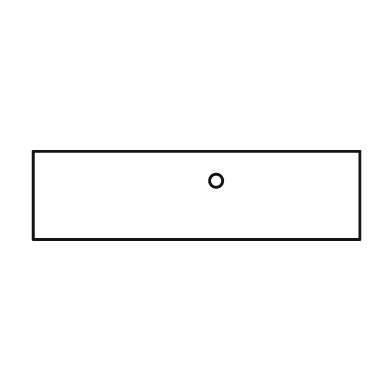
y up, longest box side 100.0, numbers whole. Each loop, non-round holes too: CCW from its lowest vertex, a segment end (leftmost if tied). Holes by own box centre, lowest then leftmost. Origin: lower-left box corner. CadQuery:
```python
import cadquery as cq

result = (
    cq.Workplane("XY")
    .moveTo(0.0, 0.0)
    .lineTo(100.0, 0.0)
    .lineTo(100.0, 27.0)
    .lineTo(0.0, 27.0)
    .close()
    .moveTo(56.0, 18.0)
    .circle(2.0)
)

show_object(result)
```